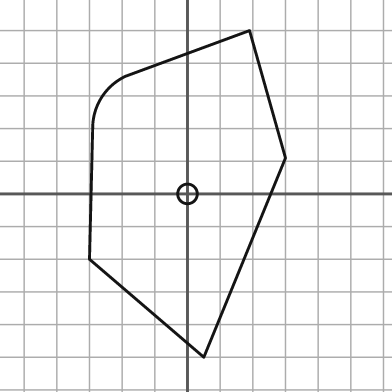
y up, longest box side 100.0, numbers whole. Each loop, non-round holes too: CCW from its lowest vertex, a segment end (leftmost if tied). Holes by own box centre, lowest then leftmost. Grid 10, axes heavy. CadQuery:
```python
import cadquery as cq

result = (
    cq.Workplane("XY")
    .moveTo(5.0, -50.0)
    .lineTo(30.0, 11.0)
    .lineTo(19.0, 50.0)
    .lineTo(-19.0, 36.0)
    .threePointArc((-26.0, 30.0), (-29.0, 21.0))
    .lineTo(-30.0, -20.0)
    .close()
    .moveTo(0.0, 0.0)
    .circle(3.0)
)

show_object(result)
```